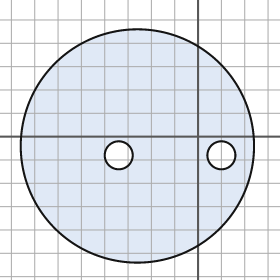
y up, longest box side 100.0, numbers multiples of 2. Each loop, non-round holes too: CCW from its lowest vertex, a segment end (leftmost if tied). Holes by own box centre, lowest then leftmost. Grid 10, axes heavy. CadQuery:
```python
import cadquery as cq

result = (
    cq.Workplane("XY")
    .moveTo(-26.0, -4.0)
    .circle(50.0)
    .moveTo(-34.0, -8.0)
    .circle(6.0)
    .moveTo(10.0, -8.0)
    .circle(6.0)
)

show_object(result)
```